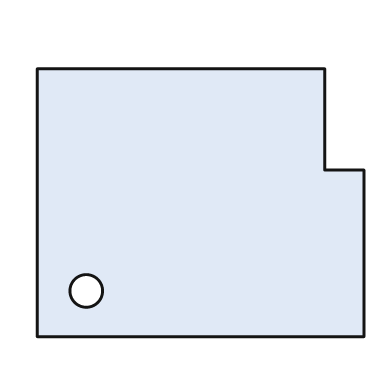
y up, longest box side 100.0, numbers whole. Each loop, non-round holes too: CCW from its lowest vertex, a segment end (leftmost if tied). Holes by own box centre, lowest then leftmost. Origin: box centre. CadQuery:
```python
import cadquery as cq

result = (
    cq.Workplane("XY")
    .moveTo(-50.0, -41.0)
    .lineTo(50.0, -41.0)
    .lineTo(50.0, 10.0)
    .lineTo(38.0, 10.0)
    .lineTo(38.0, 41.0)
    .lineTo(-50.0, 41.0)
    .close()
    .moveTo(-35.0, -27.0)
    .circle(5.0)
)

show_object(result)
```